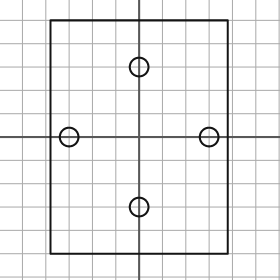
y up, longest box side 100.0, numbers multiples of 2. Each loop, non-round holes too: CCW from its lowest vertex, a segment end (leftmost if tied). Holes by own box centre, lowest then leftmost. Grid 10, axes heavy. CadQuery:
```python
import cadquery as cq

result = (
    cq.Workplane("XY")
    .moveTo(-38.0, -50.0)
    .lineTo(38.0, -50.0)
    .lineTo(38.0, 50.0)
    .lineTo(-38.0, 50.0)
    .close()
    .moveTo(0.0, -30.0)
    .circle(4.0)
    .moveTo(-30.0, 0.0)
    .circle(4.0)
    .moveTo(30.0, 0.0)
    .circle(4.0)
    .moveTo(0.0, 30.0)
    .circle(4.0)
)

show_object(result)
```